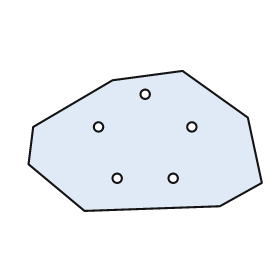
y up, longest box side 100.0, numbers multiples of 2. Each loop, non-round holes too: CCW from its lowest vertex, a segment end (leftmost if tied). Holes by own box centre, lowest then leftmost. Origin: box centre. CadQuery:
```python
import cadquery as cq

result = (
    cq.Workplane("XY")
    .moveTo(-26.0, -30.0)
    .lineTo(32.0, -28.0)
    .lineTo(50.0, -18.0)
    .lineTo(44.0, 10.0)
    .lineTo(16.0, 30.0)
    .lineTo(-14.0, 26.0)
    .lineTo(-48.0, 6.0)
    .lineTo(-50.0, -10.0)
    .close()
    .moveTo(-12.0, -16.0)
    .circle(2.0)
    .moveTo(12.0, -16.0)
    .circle(2.0)
    .moveTo(-20.0, 6.0)
    .circle(2.0)
    .moveTo(20.0, 6.0)
    .circle(2.0)
    .moveTo(0.0, 20.0)
    .circle(2.0)
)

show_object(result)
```